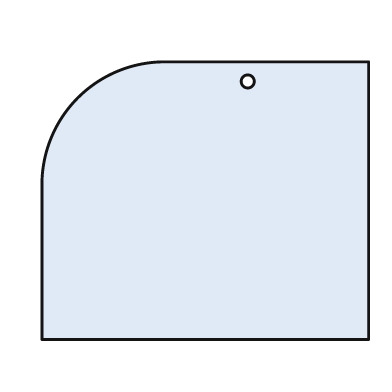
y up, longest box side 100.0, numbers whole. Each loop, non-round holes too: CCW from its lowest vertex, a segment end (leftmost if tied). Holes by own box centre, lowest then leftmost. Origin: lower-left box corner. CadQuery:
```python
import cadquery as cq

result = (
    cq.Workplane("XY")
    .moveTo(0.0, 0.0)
    .lineTo(100.0, 0.0)
    .lineTo(100.0, 85.0)
    .lineTo(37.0, 85.0)
    .threePointArc((11.0, 74.0), (0.0, 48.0))
    .close()
    .moveTo(63.0, 79.0)
    .circle(2.0)
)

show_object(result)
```